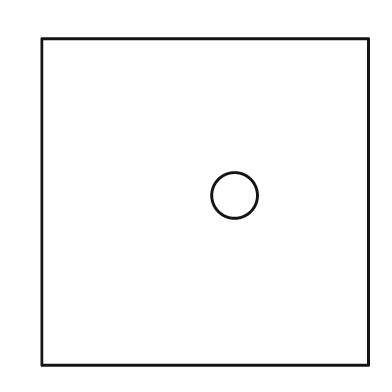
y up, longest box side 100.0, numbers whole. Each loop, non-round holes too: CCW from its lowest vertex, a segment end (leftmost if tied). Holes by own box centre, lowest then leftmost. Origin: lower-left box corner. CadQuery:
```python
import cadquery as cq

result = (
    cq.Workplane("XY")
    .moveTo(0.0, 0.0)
    .lineTo(100.0, 0.0)
    .lineTo(100.0, 100.0)
    .lineTo(0.0, 100.0)
    .close()
    .moveTo(59.0, 52.0)
    .circle(7.0)
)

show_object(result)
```